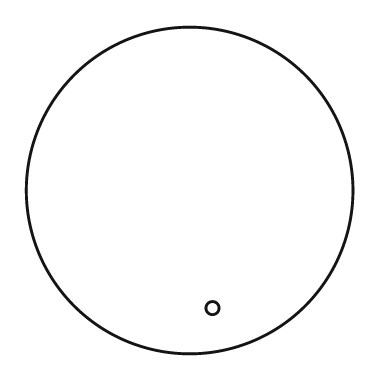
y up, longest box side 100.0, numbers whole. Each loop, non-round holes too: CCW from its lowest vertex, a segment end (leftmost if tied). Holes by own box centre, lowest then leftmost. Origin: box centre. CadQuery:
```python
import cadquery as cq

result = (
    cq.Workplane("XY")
    .moveTo(0.0, 0.0)
    .circle(50.0)
    .moveTo(7.0, -36.0)
    .circle(2.0)
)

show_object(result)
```